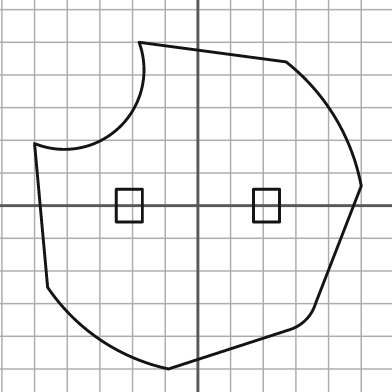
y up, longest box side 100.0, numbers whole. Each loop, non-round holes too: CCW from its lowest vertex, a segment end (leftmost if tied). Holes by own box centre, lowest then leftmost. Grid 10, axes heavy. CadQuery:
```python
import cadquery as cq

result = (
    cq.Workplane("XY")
    .moveTo(-9.0, -50.0)
    .lineTo(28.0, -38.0)
    .threePointArc((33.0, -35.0), (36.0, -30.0))
    .lineTo(50.0, 6.0)
    .threePointArc((42.0, 27.0), (27.0, 44.0))
    .lineTo(-18.0, 50.0)
    .threePointArc((-24.0, 24.0), (-50.0, 19.0))
    .lineTo(-46.0, -25.0)
    .threePointArc((-30.0, -41.0), (-9.0, -50.0))
    .close()
    .moveTo(-25.0, -5.0)
    .lineTo(-17.0, -5.0)
    .lineTo(-17.0, 5.0)
    .lineTo(-25.0, 5.0)
    .close()
    .moveTo(17.0, -5.0)
    .lineTo(25.0, -5.0)
    .lineTo(25.0, 5.0)
    .lineTo(17.0, 5.0)
    .close()
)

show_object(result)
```